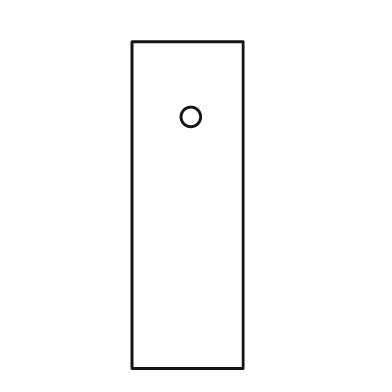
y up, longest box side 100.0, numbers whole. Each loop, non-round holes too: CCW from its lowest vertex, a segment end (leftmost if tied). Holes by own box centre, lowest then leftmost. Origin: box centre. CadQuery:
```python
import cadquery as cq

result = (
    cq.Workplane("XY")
    .moveTo(-17.0, -50.0)
    .lineTo(17.0, -50.0)
    .lineTo(17.0, 50.0)
    .lineTo(-17.0, 50.0)
    .close()
    .moveTo(1.0, 27.0)
    .circle(3.0)
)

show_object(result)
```